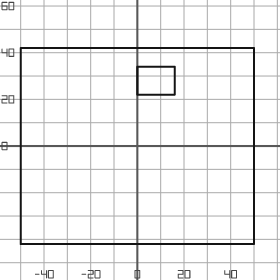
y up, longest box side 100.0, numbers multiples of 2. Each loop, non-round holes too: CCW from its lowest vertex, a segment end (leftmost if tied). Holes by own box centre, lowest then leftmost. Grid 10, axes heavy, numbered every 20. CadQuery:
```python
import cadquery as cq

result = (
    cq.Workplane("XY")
    .moveTo(-50.0, -42.0)
    .lineTo(50.0, -42.0)
    .lineTo(50.0, 42.0)
    .lineTo(-50.0, 42.0)
    .close()
    .moveTo(0.0, 22.0)
    .lineTo(16.0, 22.0)
    .lineTo(16.0, 34.0)
    .lineTo(0.0, 34.0)
    .close()
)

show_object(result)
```